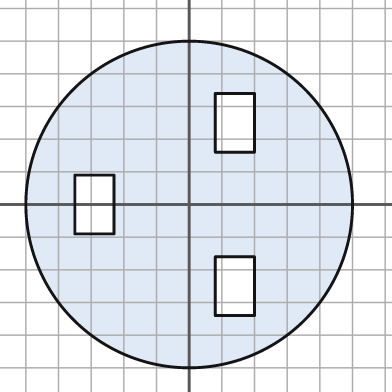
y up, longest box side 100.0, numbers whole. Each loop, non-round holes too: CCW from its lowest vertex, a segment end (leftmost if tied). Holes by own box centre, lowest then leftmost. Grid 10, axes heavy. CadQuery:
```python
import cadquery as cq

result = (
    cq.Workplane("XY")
    .moveTo(0.0, 0.0)
    .circle(50.0)
    .moveTo(8.0, -34.0)
    .lineTo(20.0, -34.0)
    .lineTo(20.0, -16.0)
    .lineTo(8.0, -16.0)
    .close()
    .moveTo(-35.0, -9.0)
    .lineTo(-23.0, -9.0)
    .lineTo(-23.0, 9.0)
    .lineTo(-35.0, 9.0)
    .close()
    .moveTo(8.0, 16.0)
    .lineTo(20.0, 16.0)
    .lineTo(20.0, 34.0)
    .lineTo(8.0, 34.0)
    .close()
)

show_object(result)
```